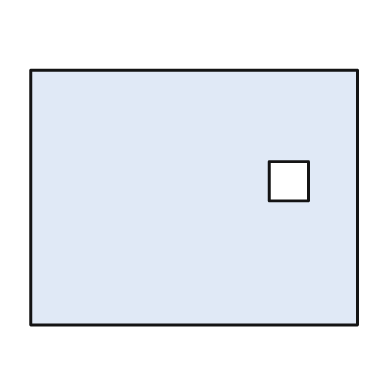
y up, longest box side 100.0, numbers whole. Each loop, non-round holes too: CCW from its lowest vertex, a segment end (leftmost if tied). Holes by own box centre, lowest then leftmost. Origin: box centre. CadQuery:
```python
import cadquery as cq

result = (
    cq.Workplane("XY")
    .moveTo(-50.0, -39.0)
    .lineTo(50.0, -39.0)
    .lineTo(50.0, 39.0)
    .lineTo(-50.0, 39.0)
    .close()
    .moveTo(23.0, -1.0)
    .lineTo(35.0, -1.0)
    .lineTo(35.0, 11.0)
    .lineTo(23.0, 11.0)
    .close()
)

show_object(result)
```